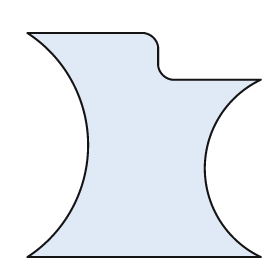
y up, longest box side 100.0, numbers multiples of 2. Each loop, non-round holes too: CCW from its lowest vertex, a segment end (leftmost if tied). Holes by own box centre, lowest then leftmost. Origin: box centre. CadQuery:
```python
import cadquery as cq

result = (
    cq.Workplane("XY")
    .moveTo(-50.0, -48.0)
    .lineTo(50.0, -48.0)
    .threePointArc((26.0, -10.0), (50.0, 28.0))
    .lineTo(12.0, 28.0)
    .threePointArc((8.0, 30.0), (6.0, 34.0))
    .lineTo(6.0, 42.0)
    .threePointArc((4.0, 46.0), (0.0, 48.0))
    .lineTo(-50.0, 48.0)
    .threePointArc((-24.0, 0.0), (-50.0, -48.0))
    .close()
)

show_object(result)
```